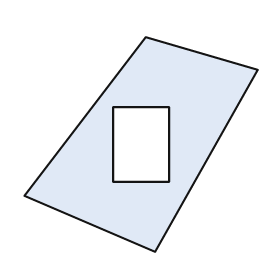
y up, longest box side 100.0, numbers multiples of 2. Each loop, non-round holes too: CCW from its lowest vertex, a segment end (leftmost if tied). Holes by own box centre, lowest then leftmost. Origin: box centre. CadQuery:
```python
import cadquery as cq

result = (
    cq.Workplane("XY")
    .moveTo(6.0, -46.0)
    .lineTo(50.0, 32.0)
    .lineTo(2.0, 46.0)
    .lineTo(-50.0, -22.0)
    .close()
    .moveTo(-12.0, -16.0)
    .lineTo(12.0, -16.0)
    .lineTo(12.0, 16.0)
    .lineTo(-12.0, 16.0)
    .close()
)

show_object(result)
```